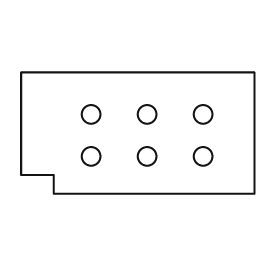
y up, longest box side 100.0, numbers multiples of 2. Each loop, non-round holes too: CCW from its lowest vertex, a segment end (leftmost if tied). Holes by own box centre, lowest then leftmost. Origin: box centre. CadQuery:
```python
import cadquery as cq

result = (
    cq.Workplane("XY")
    .moveTo(-36.0, -26.0)
    .lineTo(50.0, -26.0)
    .lineTo(50.0, 26.0)
    .lineTo(-50.0, 26.0)
    .lineTo(-50.0, -18.0)
    .lineTo(-36.0, -18.0)
    .close()
    .moveTo(-20.0, -10.0)
    .circle(4.0)
    .moveTo(4.0, -10.0)
    .circle(4.0)
    .moveTo(28.0, -10.0)
    .circle(4.0)
    .moveTo(-20.0, 8.0)
    .circle(4.0)
    .moveTo(4.0, 8.0)
    .circle(4.0)
    .moveTo(28.0, 8.0)
    .circle(4.0)
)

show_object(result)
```